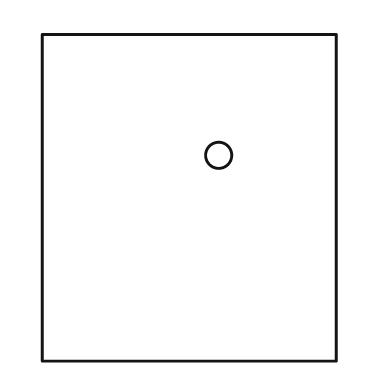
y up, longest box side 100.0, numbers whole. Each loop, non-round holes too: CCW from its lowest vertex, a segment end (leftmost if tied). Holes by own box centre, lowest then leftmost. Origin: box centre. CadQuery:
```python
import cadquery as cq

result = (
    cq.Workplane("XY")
    .moveTo(-45.0, -50.0)
    .lineTo(45.0, -50.0)
    .lineTo(45.0, 50.0)
    .lineTo(-45.0, 50.0)
    .close()
    .moveTo(9.0, 13.0)
    .circle(4.0)
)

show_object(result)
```